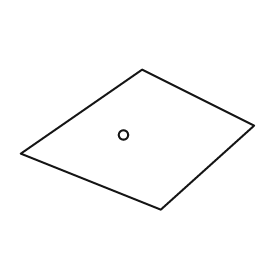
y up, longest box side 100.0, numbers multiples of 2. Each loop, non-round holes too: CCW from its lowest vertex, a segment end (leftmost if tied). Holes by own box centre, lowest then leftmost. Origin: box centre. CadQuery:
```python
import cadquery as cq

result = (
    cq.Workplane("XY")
    .moveTo(10.0, -30.0)
    .lineTo(50.0, 6.0)
    .lineTo(2.0, 30.0)
    .lineTo(-50.0, -6.0)
    .close()
    .moveTo(-6.0, 2.0)
    .circle(2.0)
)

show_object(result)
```